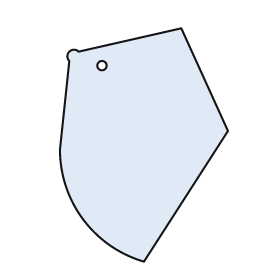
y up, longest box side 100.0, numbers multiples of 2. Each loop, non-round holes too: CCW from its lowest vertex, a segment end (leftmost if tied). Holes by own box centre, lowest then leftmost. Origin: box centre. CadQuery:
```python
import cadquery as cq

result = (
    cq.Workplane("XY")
    .moveTo(0.0, -50.0)
    .lineTo(36.0, 6.0)
    .lineTo(16.0, 50.0)
    .lineTo(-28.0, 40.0)
    .threePointArc((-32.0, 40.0), (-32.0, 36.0))
    .lineTo(-36.0, -2.0)
    .threePointArc((-26.0, -32.0), (0.0, -50.0))
    .close()
    .moveTo(-18.0, 34.0)
    .circle(2.0)
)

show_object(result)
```